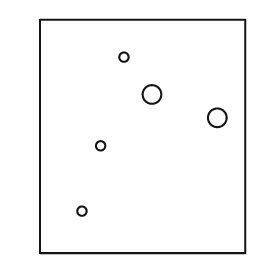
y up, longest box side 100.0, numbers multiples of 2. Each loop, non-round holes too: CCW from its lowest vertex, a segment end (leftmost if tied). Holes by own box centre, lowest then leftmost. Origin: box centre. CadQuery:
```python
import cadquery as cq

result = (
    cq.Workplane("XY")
    .moveTo(-44.0, -50.0)
    .lineTo(44.0, -50.0)
    .lineTo(44.0, 50.0)
    .lineTo(-44.0, 50.0)
    .close()
    .moveTo(-26.0, -32.0)
    .circle(2.0)
    .moveTo(-18.0, -4.0)
    .circle(2.0)
    .moveTo(32.0, 8.0)
    .circle(4.0)
    .moveTo(4.0, 18.0)
    .circle(4.0)
    .moveTo(-8.0, 34.0)
    .circle(2.0)
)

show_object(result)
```